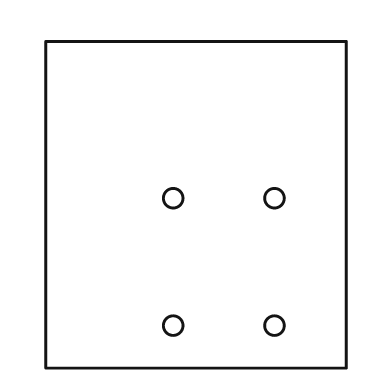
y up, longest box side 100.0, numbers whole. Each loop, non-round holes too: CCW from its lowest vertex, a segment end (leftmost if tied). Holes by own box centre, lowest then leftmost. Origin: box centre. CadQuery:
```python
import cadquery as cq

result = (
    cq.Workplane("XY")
    .moveTo(-46.0, -50.0)
    .lineTo(46.0, -50.0)
    .lineTo(46.0, 50.0)
    .lineTo(-46.0, 50.0)
    .close()
    .moveTo(-7.0, -37.0)
    .circle(3.0)
    .moveTo(24.0, -37.0)
    .circle(3.0)
    .moveTo(-7.0, 2.0)
    .circle(3.0)
    .moveTo(24.0, 2.0)
    .circle(3.0)
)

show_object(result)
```